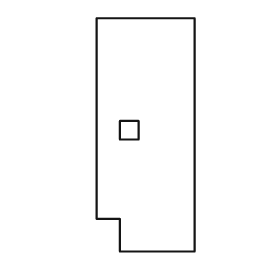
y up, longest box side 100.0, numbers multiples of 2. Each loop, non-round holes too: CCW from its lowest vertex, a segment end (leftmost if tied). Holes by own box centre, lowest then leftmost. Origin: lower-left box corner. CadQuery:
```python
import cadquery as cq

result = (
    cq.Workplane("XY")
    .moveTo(10.0, 0.0)
    .lineTo(42.0, 0.0)
    .lineTo(42.0, 100.0)
    .lineTo(0.0, 100.0)
    .lineTo(0.0, 14.0)
    .lineTo(10.0, 14.0)
    .close()
    .moveTo(10.0, 48.0)
    .lineTo(18.0, 48.0)
    .lineTo(18.0, 56.0)
    .lineTo(10.0, 56.0)
    .close()
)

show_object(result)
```